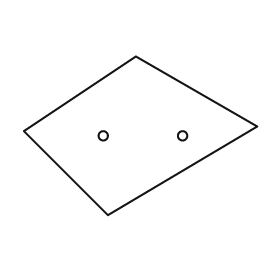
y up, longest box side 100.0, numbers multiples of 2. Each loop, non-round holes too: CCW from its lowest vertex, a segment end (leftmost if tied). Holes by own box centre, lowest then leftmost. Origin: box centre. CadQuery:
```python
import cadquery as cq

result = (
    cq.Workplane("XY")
    .moveTo(-14.0, -34.0)
    .lineTo(50.0, 4.0)
    .lineTo(-2.0, 34.0)
    .lineTo(-50.0, 2.0)
    .close()
    .moveTo(-16.0, 0.0)
    .circle(2.0)
    .moveTo(18.0, 0.0)
    .circle(2.0)
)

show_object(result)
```